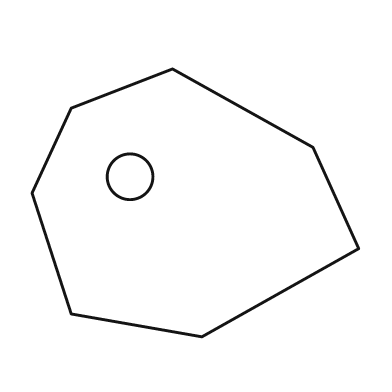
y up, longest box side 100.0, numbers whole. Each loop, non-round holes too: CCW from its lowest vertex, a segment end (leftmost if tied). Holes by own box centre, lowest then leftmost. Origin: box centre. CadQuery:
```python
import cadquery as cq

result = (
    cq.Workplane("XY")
    .moveTo(2.0, -41.0)
    .lineTo(50.0, -14.0)
    .lineTo(36.0, 17.0)
    .lineTo(-7.0, 41.0)
    .lineTo(-38.0, 29.0)
    .lineTo(-50.0, 3.0)
    .lineTo(-38.0, -34.0)
    .close()
    .moveTo(-20.0, 8.0)
    .circle(7.0)
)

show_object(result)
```